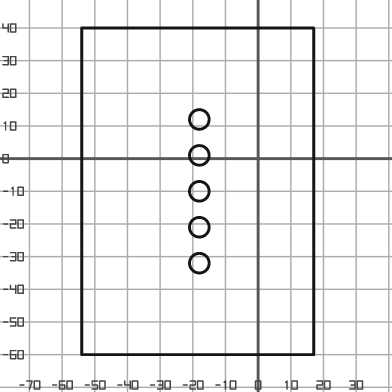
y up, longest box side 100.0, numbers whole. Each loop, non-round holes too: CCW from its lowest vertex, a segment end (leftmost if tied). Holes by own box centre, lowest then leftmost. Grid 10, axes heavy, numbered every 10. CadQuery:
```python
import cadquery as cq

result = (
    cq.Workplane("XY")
    .moveTo(-54.0, -60.0)
    .lineTo(17.0, -60.0)
    .lineTo(17.0, 40.0)
    .lineTo(-54.0, 40.0)
    .close()
    .moveTo(-18.0, -32.0)
    .circle(3.0)
    .moveTo(-18.0, -21.0)
    .circle(3.0)
    .moveTo(-18.0, -10.0)
    .circle(3.0)
    .moveTo(-18.0, 1.0)
    .circle(3.0)
    .moveTo(-18.0, 12.0)
    .circle(3.0)
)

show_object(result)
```